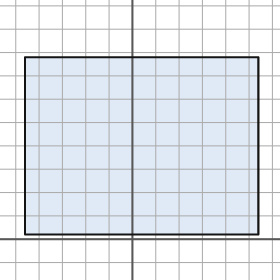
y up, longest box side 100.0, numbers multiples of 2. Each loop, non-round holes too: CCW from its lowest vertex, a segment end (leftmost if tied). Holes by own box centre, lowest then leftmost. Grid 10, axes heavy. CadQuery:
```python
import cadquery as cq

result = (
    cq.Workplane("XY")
    .moveTo(-46.0, 2.0)
    .lineTo(54.0, 2.0)
    .lineTo(54.0, 78.0)
    .lineTo(-46.0, 78.0)
    .close()
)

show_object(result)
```